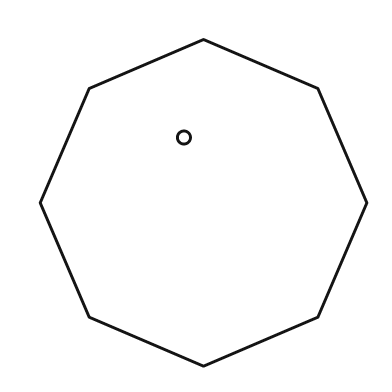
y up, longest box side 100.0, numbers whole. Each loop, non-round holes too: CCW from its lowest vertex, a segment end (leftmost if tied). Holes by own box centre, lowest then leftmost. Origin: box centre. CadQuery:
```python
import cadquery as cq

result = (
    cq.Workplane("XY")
    .moveTo(0.0, -50.0)
    .lineTo(35.0, -35.0)
    .lineTo(50.0, 0.0)
    .lineTo(35.0, 35.0)
    .lineTo(0.0, 50.0)
    .lineTo(-35.0, 35.0)
    .lineTo(-50.0, 0.0)
    .lineTo(-35.0, -35.0)
    .close()
    .moveTo(-6.0, 20.0)
    .circle(2.0)
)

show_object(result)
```